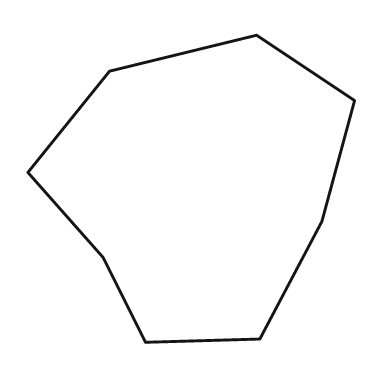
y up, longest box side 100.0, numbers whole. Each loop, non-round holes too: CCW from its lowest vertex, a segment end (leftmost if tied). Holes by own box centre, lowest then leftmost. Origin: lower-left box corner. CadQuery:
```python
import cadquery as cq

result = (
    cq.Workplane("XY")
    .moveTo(36.0, 0.0)
    .lineTo(71.0, 1.0)
    .lineTo(90.0, 37.0)
    .lineTo(100.0, 74.0)
    .lineTo(70.0, 94.0)
    .lineTo(25.0, 83.0)
    .lineTo(0.0, 52.0)
    .lineTo(23.0, 26.0)
    .close()
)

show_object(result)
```